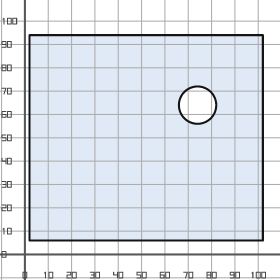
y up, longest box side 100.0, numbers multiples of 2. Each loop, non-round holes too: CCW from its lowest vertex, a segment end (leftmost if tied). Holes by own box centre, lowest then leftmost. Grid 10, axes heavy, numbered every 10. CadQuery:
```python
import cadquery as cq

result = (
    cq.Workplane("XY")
    .moveTo(2.0, 6.0)
    .lineTo(102.0, 6.0)
    .lineTo(102.0, 94.0)
    .lineTo(2.0, 94.0)
    .close()
    .moveTo(74.0, 64.0)
    .circle(8.0)
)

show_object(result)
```